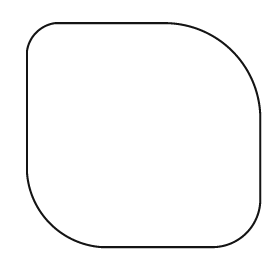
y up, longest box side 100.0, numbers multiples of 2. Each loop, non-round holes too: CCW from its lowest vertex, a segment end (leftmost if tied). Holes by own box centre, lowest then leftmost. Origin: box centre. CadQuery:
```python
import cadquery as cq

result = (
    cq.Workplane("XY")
    .moveTo(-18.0, -48.0)
    .lineTo(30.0, -48.0)
    .threePointArc((44.0, -42.0), (50.0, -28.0))
    .lineTo(50.0, 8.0)
    .threePointArc((38.0, 36.0), (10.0, 48.0))
    .lineTo(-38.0, 48.0)
    .threePointArc((-46.0, 44.0), (-50.0, 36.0))
    .lineTo(-50.0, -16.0)
    .threePointArc((-40.0, -38.0), (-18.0, -48.0))
    .close()
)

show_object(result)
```